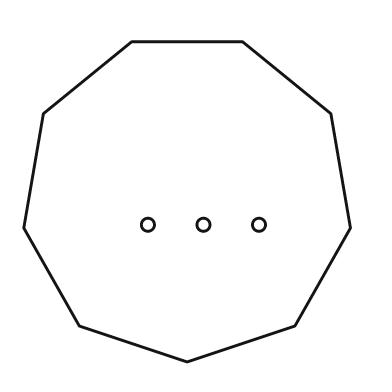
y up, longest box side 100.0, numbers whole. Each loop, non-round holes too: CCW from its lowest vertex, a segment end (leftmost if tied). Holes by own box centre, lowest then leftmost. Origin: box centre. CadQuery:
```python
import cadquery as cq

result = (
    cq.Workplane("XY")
    .moveTo(0.0, -49.0)
    .lineTo(33.0, -38.0)
    .lineTo(50.0, -8.0)
    .lineTo(44.0, 27.0)
    .lineTo(17.0, 49.0)
    .lineTo(-17.0, 49.0)
    .lineTo(-44.0, 27.0)
    .lineTo(-50.0, -8.0)
    .lineTo(-33.0, -38.0)
    .close()
    .moveTo(-12.0, -7.0)
    .circle(2.0)
    .moveTo(5.0, -7.0)
    .circle(2.0)
    .moveTo(22.0, -7.0)
    .circle(2.0)
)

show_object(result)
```